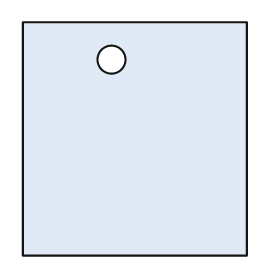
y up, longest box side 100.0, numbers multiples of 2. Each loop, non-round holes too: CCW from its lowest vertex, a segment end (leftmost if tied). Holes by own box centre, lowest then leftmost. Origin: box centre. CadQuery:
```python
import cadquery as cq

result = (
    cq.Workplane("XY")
    .moveTo(-48.0, -50.0)
    .lineTo(48.0, -50.0)
    .lineTo(48.0, 50.0)
    .lineTo(-48.0, 50.0)
    .close()
    .moveTo(-10.0, 34.0)
    .circle(6.0)
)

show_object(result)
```